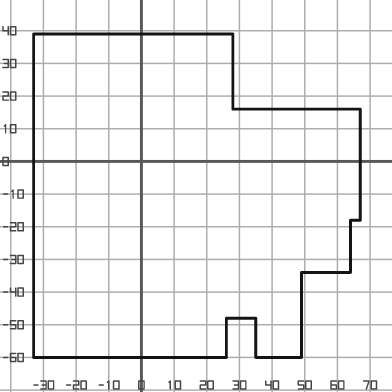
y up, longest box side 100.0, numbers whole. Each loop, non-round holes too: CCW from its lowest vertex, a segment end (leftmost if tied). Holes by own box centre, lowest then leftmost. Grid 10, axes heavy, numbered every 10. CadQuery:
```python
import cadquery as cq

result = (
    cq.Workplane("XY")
    .moveTo(-33.0, -60.0)
    .lineTo(26.0, -60.0)
    .lineTo(26.0, -48.0)
    .lineTo(35.0, -48.0)
    .lineTo(35.0, -60.0)
    .lineTo(49.0, -60.0)
    .lineTo(49.0, -34.0)
    .lineTo(64.0, -34.0)
    .lineTo(64.0, -18.0)
    .lineTo(67.0, -18.0)
    .lineTo(67.0, 16.0)
    .lineTo(28.0, 16.0)
    .lineTo(28.0, 39.0)
    .lineTo(-33.0, 39.0)
    .close()
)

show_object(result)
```